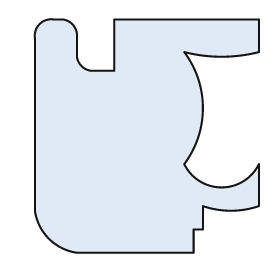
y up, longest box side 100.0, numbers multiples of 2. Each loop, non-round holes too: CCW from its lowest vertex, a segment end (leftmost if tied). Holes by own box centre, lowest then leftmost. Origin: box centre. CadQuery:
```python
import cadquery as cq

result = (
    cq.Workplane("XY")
    .moveTo(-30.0, -50.0)
    .lineTo(20.0, -50.0)
    .lineTo(20.0, -40.0)
    .lineTo(24.0, -40.0)
    .lineTo(24.0, -30.0)
    .threePointArc((36.0, -32.0), (48.0, -30.0))
    .lineTo(48.0, -12.0)
    .threePointArc((32.0, -22.0), (16.0, -12.0))
    .threePointArc((24.0, 12.0), (16.0, 36.0))
    .threePointArc((32.0, 34.0), (48.0, 36.0))
    .lineTo(48.0, 50.0)
    .lineTo(-14.0, 50.0)
    .lineTo(-14.0, 28.0)
    .lineTo(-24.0, 28.0)
    .threePointArc((-28.0, 30.0), (-30.0, 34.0))
    .lineTo(-30.0, 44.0)
    .threePointArc((-32.0, 48.0), (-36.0, 50.0))
    .lineTo(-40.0, 50.0)
    .threePointArc((-46.0, 48.0), (-48.0, 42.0))
    .lineTo(-48.0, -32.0)
    .threePointArc((-42.0, -44.0), (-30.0, -50.0))
    .close()
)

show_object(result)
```